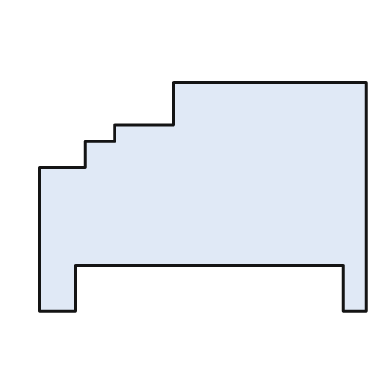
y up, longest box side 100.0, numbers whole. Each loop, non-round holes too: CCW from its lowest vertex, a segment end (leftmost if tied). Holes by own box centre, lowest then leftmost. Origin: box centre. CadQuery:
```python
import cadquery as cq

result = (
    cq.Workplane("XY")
    .moveTo(-50.0, -35.0)
    .lineTo(-39.0, -35.0)
    .lineTo(-39.0, -21.0)
    .lineTo(43.0, -21.0)
    .lineTo(43.0, -35.0)
    .lineTo(50.0, -35.0)
    .lineTo(50.0, 35.0)
    .lineTo(-9.0, 35.0)
    .lineTo(-9.0, 22.0)
    .lineTo(-27.0, 22.0)
    .lineTo(-27.0, 17.0)
    .lineTo(-36.0, 17.0)
    .lineTo(-36.0, 9.0)
    .lineTo(-50.0, 9.0)
    .close()
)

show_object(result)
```